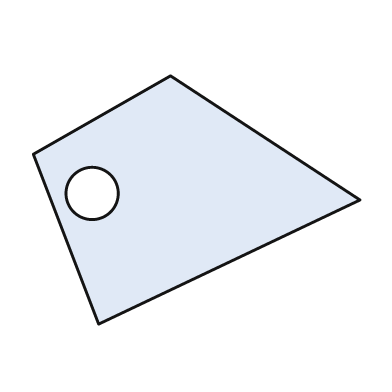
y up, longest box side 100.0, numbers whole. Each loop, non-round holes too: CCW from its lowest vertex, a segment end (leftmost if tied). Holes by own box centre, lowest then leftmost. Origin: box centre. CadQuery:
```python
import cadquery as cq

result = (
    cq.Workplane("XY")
    .moveTo(-30.0, -38.0)
    .lineTo(50.0, 0.0)
    .lineTo(-8.0, 38.0)
    .lineTo(-50.0, 14.0)
    .close()
    .moveTo(-32.0, 2.0)
    .circle(8.0)
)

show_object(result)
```